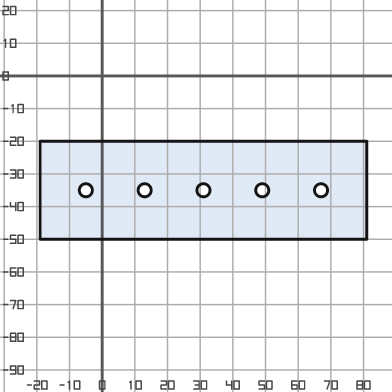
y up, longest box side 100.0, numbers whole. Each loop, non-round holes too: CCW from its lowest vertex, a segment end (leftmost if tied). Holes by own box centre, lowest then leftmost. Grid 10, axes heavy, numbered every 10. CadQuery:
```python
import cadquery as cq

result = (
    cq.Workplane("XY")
    .moveTo(-19.0, -50.0)
    .lineTo(81.0, -50.0)
    .lineTo(81.0, -20.0)
    .lineTo(-19.0, -20.0)
    .close()
    .moveTo(-5.0, -35.0)
    .circle(2.0)
    .moveTo(13.0, -35.0)
    .circle(2.0)
    .moveTo(31.0, -35.0)
    .circle(2.0)
    .moveTo(49.0, -35.0)
    .circle(2.0)
    .moveTo(67.0, -35.0)
    .circle(2.0)
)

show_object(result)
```